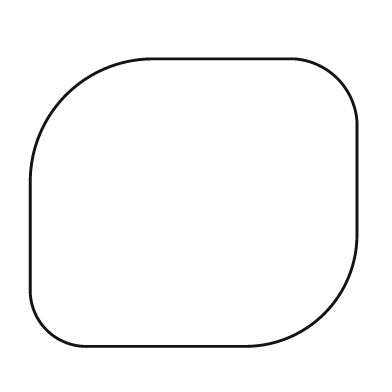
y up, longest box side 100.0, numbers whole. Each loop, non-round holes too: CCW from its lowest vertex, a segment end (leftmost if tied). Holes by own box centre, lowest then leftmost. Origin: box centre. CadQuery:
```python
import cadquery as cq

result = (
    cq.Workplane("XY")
    .moveTo(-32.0, -44.0)
    .lineTo(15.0, -44.0)
    .threePointArc((40.0, -34.0), (50.0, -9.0))
    .lineTo(50.0, 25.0)
    .threePointArc((44.0, 38.0), (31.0, 44.0))
    .lineTo(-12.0, 44.0)
    .threePointArc((-39.0, 33.0), (-50.0, 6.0))
    .lineTo(-50.0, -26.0)
    .threePointArc((-45.0, -39.0), (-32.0, -44.0))
    .close()
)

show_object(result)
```